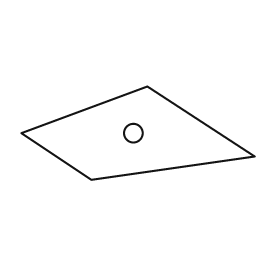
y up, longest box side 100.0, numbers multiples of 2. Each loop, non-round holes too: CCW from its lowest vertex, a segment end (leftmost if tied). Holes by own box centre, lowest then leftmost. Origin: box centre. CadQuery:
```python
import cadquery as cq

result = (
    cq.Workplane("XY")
    .moveTo(-20.0, -20.0)
    .lineTo(50.0, -10.0)
    .lineTo(4.0, 20.0)
    .lineTo(-50.0, 0.0)
    .close()
    .moveTo(-2.0, 0.0)
    .circle(4.0)
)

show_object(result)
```